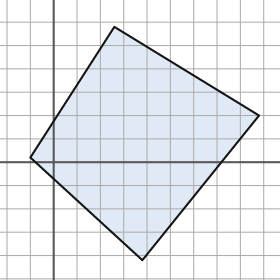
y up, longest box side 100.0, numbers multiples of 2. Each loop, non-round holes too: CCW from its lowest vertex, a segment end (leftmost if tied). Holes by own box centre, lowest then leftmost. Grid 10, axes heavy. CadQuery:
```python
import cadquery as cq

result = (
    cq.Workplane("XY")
    .moveTo(38.0, -42.0)
    .lineTo(88.0, 20.0)
    .lineTo(26.0, 58.0)
    .lineTo(-10.0, 2.0)
    .close()
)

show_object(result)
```